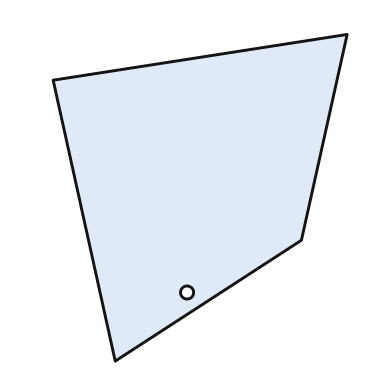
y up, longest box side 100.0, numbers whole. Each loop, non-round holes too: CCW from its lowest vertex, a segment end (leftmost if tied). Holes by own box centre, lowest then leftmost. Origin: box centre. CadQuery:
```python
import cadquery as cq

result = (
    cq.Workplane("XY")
    .moveTo(-26.0, -50.0)
    .lineTo(31.0, -13.0)
    .lineTo(45.0, 50.0)
    .lineTo(-45.0, 36.0)
    .close()
    .moveTo(-4.0, -29.0)
    .circle(2.0)
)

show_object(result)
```